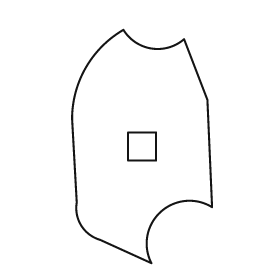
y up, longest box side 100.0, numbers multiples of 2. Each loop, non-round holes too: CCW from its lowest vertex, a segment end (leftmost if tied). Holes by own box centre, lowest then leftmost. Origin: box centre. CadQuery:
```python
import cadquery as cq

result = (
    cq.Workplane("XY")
    .moveTo(4.0, -50.0)
    .threePointArc((8.0, -28.0), (30.0, -26.0))
    .lineTo(28.0, 20.0)
    .lineTo(18.0, 46.0)
    .threePointArc((4.0, 42.0), (-8.0, 50.0))
    .threePointArc((-24.0, 34.0), (-30.0, 12.0))
    .lineTo(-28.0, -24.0)
    .threePointArc((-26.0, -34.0), (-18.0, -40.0))
    .close()
    .moveTo(-6.0, -6.0)
    .lineTo(6.0, -6.0)
    .lineTo(6.0, 6.0)
    .lineTo(-6.0, 6.0)
    .close()
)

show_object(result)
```